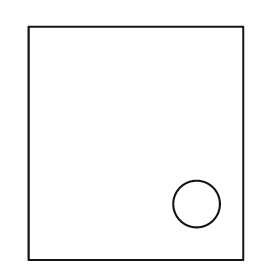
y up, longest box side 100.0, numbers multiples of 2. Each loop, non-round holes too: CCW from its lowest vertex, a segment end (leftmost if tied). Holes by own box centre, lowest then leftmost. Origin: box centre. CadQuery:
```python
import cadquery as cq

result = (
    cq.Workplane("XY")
    .moveTo(-46.0, -50.0)
    .lineTo(46.0, -50.0)
    .lineTo(46.0, 50.0)
    .lineTo(-46.0, 50.0)
    .close()
    .moveTo(26.0, -26.0)
    .circle(10.0)
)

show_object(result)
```